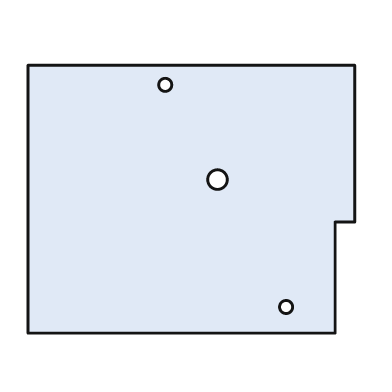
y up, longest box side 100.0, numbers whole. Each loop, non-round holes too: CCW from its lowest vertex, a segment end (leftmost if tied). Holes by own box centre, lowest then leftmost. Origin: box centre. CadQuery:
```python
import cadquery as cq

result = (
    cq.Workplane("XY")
    .moveTo(-50.0, -41.0)
    .lineTo(44.0, -41.0)
    .lineTo(44.0, -7.0)
    .lineTo(50.0, -7.0)
    .lineTo(50.0, 41.0)
    .lineTo(-50.0, 41.0)
    .close()
    .moveTo(29.0, -33.0)
    .circle(2.0)
    .moveTo(8.0, 6.0)
    .circle(3.0)
    .moveTo(-8.0, 35.0)
    .circle(2.0)
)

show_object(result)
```